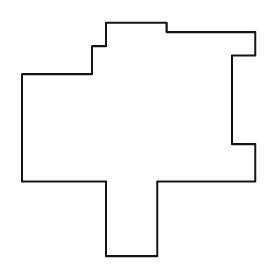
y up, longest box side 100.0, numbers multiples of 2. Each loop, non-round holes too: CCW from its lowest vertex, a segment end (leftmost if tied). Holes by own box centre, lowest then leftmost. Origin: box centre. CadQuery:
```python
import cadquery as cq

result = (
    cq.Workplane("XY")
    .moveTo(-14.0, -50.0)
    .lineTo(8.0, -50.0)
    .lineTo(8.0, -18.0)
    .lineTo(50.0, -18.0)
    .lineTo(50.0, -2.0)
    .lineTo(40.0, -2.0)
    .lineTo(40.0, 36.0)
    .lineTo(50.0, 36.0)
    .lineTo(50.0, 46.0)
    .lineTo(12.0, 46.0)
    .lineTo(12.0, 50.0)
    .lineTo(-14.0, 50.0)
    .lineTo(-14.0, 40.0)
    .lineTo(-20.0, 40.0)
    .lineTo(-20.0, 28.0)
    .lineTo(-50.0, 28.0)
    .lineTo(-50.0, -18.0)
    .lineTo(-14.0, -18.0)
    .close()
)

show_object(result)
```